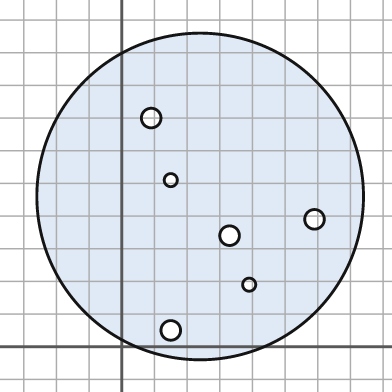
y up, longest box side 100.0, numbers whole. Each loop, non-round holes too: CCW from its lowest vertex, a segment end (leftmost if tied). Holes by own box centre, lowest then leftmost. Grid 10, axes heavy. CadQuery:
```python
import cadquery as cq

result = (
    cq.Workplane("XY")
    .moveTo(24.0, 46.0)
    .circle(50.0)
    .moveTo(15.0, 5.0)
    .circle(3.0)
    .moveTo(39.0, 19.0)
    .circle(2.0)
    .moveTo(33.0, 34.0)
    .circle(3.0)
    .moveTo(59.0, 39.0)
    .circle(3.0)
    .moveTo(15.0, 51.0)
    .circle(2.0)
    .moveTo(9.0, 70.0)
    .circle(3.0)
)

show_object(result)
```